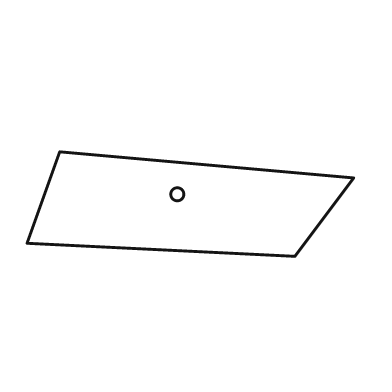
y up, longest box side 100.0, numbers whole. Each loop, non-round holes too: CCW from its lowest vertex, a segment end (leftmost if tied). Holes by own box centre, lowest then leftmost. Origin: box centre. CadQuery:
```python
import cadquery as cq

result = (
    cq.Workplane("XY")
    .moveTo(32.0, -16.0)
    .lineTo(50.0, 8.0)
    .lineTo(-40.0, 16.0)
    .lineTo(-50.0, -12.0)
    .close()
    .moveTo(-4.0, 3.0)
    .circle(2.0)
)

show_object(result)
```